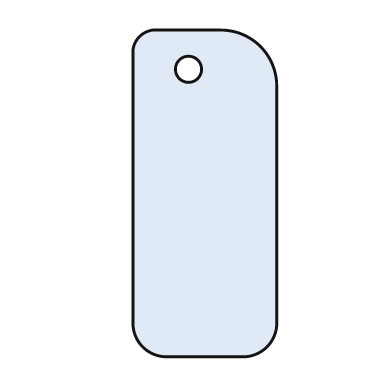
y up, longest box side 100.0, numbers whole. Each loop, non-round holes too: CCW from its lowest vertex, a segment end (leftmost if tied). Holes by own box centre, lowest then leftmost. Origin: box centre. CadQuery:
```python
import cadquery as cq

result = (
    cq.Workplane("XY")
    .moveTo(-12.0, -50.0)
    .lineTo(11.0, -50.0)
    .threePointArc((19.0, -47.0), (22.0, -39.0))
    .lineTo(22.0, 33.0)
    .threePointArc((17.0, 45.0), (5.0, 50.0))
    .lineTo(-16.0, 50.0)
    .threePointArc((-20.0, 48.0), (-22.0, 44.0))
    .lineTo(-22.0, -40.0)
    .threePointArc((-19.0, -47.0), (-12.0, -50.0))
    .close()
    .moveTo(-5.0, 38.0)
    .circle(4.0)
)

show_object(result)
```